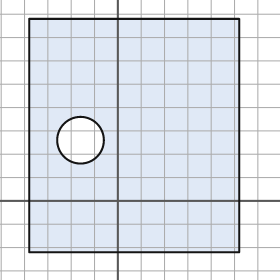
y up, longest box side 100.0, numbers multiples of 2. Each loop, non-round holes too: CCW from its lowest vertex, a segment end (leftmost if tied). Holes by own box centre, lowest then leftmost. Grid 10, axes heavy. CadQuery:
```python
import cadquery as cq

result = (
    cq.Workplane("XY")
    .moveTo(-38.0, -22.0)
    .lineTo(52.0, -22.0)
    .lineTo(52.0, 78.0)
    .lineTo(-38.0, 78.0)
    .close()
    .moveTo(-16.0, 26.0)
    .circle(10.0)
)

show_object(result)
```